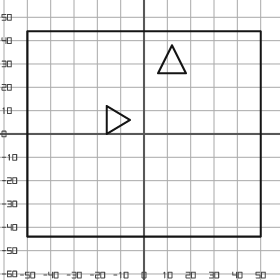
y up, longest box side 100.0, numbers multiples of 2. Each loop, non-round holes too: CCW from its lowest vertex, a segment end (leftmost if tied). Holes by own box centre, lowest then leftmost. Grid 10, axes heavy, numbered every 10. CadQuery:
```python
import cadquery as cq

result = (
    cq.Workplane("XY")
    .moveTo(-50.0, -44.0)
    .lineTo(50.0, -44.0)
    .lineTo(50.0, 44.0)
    .lineTo(-50.0, 44.0)
    .close()
    .moveTo(-16.0, 0.0)
    .lineTo(-6.0, 6.0)
    .lineTo(-16.0, 12.0)
    .close()
    .moveTo(6.0, 26.0)
    .lineTo(18.0, 26.0)
    .lineTo(12.0, 38.0)
    .close()
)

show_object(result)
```